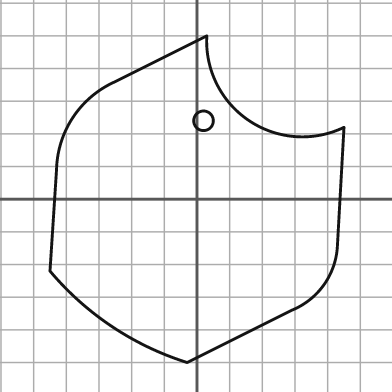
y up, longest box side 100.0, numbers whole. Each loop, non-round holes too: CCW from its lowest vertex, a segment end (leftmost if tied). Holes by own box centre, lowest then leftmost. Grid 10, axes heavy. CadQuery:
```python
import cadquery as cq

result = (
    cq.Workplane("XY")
    .moveTo(-3.0, -50.0)
    .lineTo(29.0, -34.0)
    .threePointArc((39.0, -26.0), (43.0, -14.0))
    .lineTo(45.0, 22.0)
    .threePointArc((16.0, 24.0), (3.0, 50.0))
    .lineTo(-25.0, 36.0)
    .threePointArc((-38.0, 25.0), (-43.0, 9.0))
    .lineTo(-45.0, -22.0)
    .threePointArc((-26.0, -39.0), (-3.0, -50.0))
    .close()
    .moveTo(2.0, 24.0)
    .circle(3.0)
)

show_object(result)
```